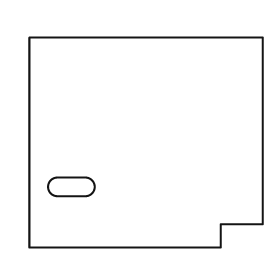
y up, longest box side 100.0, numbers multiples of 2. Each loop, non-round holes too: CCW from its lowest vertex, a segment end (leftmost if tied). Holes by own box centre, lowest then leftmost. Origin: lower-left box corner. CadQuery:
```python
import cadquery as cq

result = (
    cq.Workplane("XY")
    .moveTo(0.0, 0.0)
    .lineTo(82.0, 0.0)
    .lineTo(82.0, 10.0)
    .lineTo(100.0, 10.0)
    .lineTo(100.0, 90.0)
    .lineTo(0.0, 90.0)
    .close()
    .moveTo(12.0, 22.0)
    .lineTo(24.0, 22.0)
    .threePointArc((28.0, 26.0), (24.0, 30.0))
    .lineTo(12.0, 30.0)
    .threePointArc((8.0, 26.0), (12.0, 22.0))
    .close()
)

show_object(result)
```